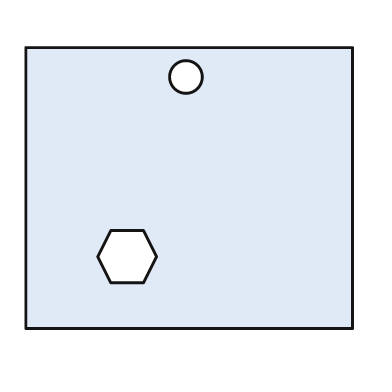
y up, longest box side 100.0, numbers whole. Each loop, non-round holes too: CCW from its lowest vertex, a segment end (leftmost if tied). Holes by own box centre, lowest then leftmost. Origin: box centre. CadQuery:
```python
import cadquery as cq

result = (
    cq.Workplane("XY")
    .moveTo(-50.0, -43.0)
    .lineTo(50.0, -43.0)
    .lineTo(50.0, 43.0)
    .lineTo(-50.0, 43.0)
    .close()
    .moveTo(-24.0, -29.0)
    .lineTo(-14.0, -29.0)
    .lineTo(-10.0, -21.0)
    .lineTo(-14.0, -13.0)
    .lineTo(-24.0, -13.0)
    .lineTo(-28.0, -21.0)
    .close()
    .moveTo(-1.0, 34.0)
    .circle(5.0)
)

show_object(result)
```